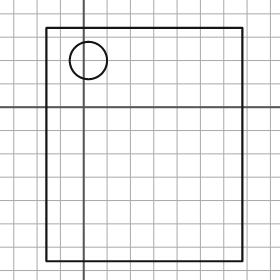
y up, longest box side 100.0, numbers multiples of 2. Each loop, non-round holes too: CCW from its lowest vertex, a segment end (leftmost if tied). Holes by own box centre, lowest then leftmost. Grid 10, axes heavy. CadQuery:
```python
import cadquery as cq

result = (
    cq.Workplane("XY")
    .moveTo(-16.0, -66.0)
    .lineTo(68.0, -66.0)
    .lineTo(68.0, 34.0)
    .lineTo(-16.0, 34.0)
    .close()
    .moveTo(2.0, 20.0)
    .circle(8.0)
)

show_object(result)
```